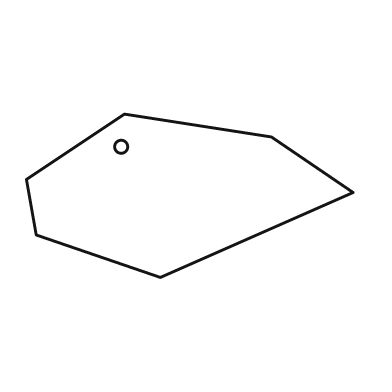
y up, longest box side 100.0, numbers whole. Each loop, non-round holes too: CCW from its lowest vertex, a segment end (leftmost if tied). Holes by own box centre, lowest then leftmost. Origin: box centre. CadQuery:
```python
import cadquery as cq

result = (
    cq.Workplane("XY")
    .moveTo(-9.0, -25.0)
    .lineTo(50.0, 1.0)
    .lineTo(25.0, 18.0)
    .lineTo(-20.0, 25.0)
    .lineTo(-50.0, 5.0)
    .lineTo(-47.0, -12.0)
    .close()
    .moveTo(-21.0, 15.0)
    .circle(2.0)
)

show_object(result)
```